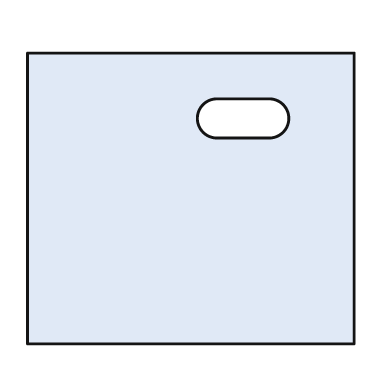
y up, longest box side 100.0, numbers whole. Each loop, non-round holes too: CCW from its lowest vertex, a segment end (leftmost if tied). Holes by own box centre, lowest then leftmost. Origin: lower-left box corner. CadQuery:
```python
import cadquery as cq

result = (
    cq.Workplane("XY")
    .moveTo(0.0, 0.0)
    .lineTo(100.0, 0.0)
    .lineTo(100.0, 89.0)
    .lineTo(0.0, 89.0)
    .close()
    .moveTo(58.0, 63.0)
    .lineTo(74.0, 63.0)
    .threePointArc((80.0, 69.0), (74.0, 75.0))
    .lineTo(58.0, 75.0)
    .threePointArc((52.0, 69.0), (58.0, 63.0))
    .close()
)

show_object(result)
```